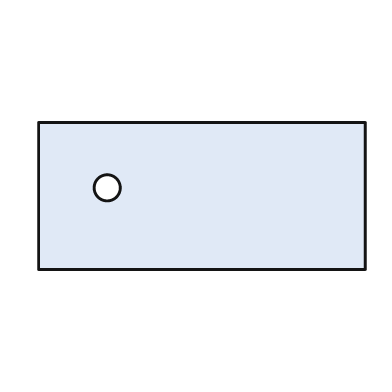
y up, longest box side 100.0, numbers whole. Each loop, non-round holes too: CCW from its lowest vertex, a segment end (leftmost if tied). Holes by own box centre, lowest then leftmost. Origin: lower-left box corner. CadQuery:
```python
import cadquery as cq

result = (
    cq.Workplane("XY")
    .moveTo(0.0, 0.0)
    .lineTo(100.0, 0.0)
    .lineTo(100.0, 45.0)
    .lineTo(0.0, 45.0)
    .close()
    .moveTo(21.0, 25.0)
    .circle(4.0)
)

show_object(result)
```